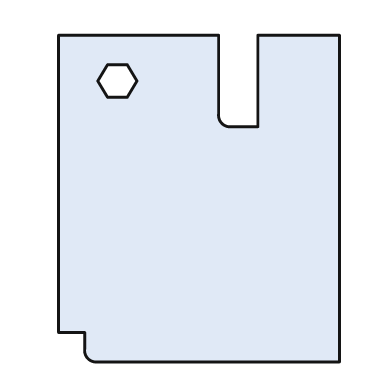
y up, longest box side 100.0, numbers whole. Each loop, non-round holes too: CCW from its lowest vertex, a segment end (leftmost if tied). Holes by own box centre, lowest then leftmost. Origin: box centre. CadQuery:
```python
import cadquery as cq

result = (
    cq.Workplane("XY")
    .moveTo(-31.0, -50.0)
    .lineTo(43.0, -50.0)
    .lineTo(43.0, 50.0)
    .lineTo(18.0, 50.0)
    .lineTo(18.0, 22.0)
    .lineTo(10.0, 22.0)
    .threePointArc((7.0, 23.0), (6.0, 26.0))
    .lineTo(6.0, 50.0)
    .lineTo(-43.0, 50.0)
    .lineTo(-43.0, -41.0)
    .lineTo(-35.0, -41.0)
    .lineTo(-35.0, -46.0)
    .threePointArc((-34.0, -49.0), (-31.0, -50.0))
    .close()
    .moveTo(-28.0, 31.0)
    .lineTo(-22.0, 31.0)
    .lineTo(-19.0, 36.0)
    .lineTo(-22.0, 41.0)
    .lineTo(-28.0, 41.0)
    .lineTo(-31.0, 36.0)
    .close()
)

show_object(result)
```